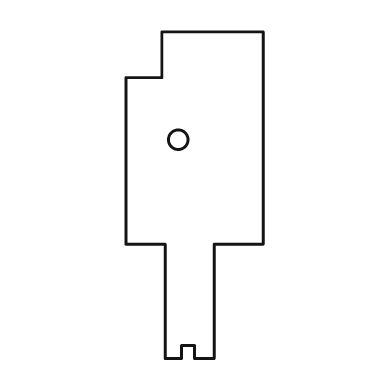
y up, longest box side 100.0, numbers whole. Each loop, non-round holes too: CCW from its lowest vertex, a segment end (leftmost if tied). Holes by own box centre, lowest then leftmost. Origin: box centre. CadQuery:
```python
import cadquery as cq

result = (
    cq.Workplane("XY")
    .moveTo(-9.0, -50.0)
    .lineTo(-4.0, -50.0)
    .lineTo(-4.0, -46.0)
    .lineTo(0.0, -46.0)
    .lineTo(0.0, -50.0)
    .lineTo(6.0, -50.0)
    .lineTo(6.0, -15.0)
    .lineTo(21.0, -15.0)
    .lineTo(21.0, 50.0)
    .lineTo(-10.0, 50.0)
    .lineTo(-10.0, 36.0)
    .lineTo(-21.0, 36.0)
    .lineTo(-21.0, -15.0)
    .lineTo(-9.0, -15.0)
    .close()
    .moveTo(-5.0, 17.0)
    .circle(3.0)
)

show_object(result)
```